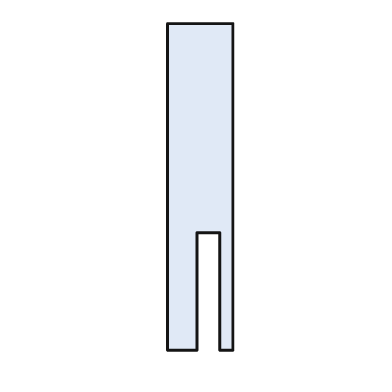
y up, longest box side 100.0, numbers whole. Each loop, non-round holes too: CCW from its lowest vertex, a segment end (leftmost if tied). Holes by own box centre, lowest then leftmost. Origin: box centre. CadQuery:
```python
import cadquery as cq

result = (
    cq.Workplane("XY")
    .moveTo(-10.0, -50.0)
    .lineTo(-1.0, -50.0)
    .lineTo(-1.0, -14.0)
    .lineTo(6.0, -14.0)
    .lineTo(6.0, -50.0)
    .lineTo(10.0, -50.0)
    .lineTo(10.0, 50.0)
    .lineTo(-10.0, 50.0)
    .close()
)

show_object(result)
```